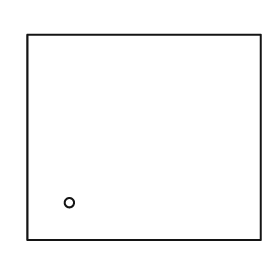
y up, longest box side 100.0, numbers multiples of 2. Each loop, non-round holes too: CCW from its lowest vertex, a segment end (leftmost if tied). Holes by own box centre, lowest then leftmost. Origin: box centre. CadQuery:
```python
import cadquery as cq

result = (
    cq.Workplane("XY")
    .moveTo(-50.0, -44.0)
    .lineTo(50.0, -44.0)
    .lineTo(50.0, 44.0)
    .lineTo(-50.0, 44.0)
    .close()
    .moveTo(-32.0, -28.0)
    .circle(2.0)
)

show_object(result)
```